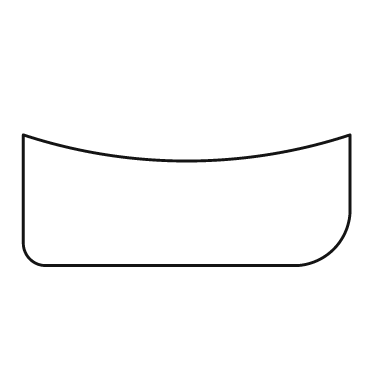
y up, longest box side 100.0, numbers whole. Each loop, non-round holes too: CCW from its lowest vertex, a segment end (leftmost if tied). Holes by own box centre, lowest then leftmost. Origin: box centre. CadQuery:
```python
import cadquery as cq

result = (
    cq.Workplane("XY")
    .moveTo(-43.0, -20.0)
    .lineTo(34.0, -20.0)
    .threePointArc((45.0, -15.0), (50.0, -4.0))
    .lineTo(50.0, 20.0)
    .threePointArc((0.0, 12.0), (-50.0, 20.0))
    .lineTo(-50.0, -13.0)
    .threePointArc((-48.0, -18.0), (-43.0, -20.0))
    .close()
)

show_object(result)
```